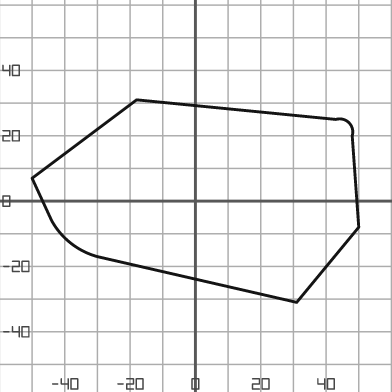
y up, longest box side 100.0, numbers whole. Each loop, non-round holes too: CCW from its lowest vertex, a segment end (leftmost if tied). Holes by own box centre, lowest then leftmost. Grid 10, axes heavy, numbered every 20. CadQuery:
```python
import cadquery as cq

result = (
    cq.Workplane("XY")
    .moveTo(31.0, -31.0)
    .lineTo(50.0, -8.0)
    .lineTo(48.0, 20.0)
    .threePointArc((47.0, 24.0), (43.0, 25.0))
    .lineTo(-18.0, 31.0)
    .lineTo(-50.0, 7.0)
    .lineTo(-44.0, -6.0)
    .threePointArc((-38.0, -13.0), (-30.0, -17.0))
    .close()
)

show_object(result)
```